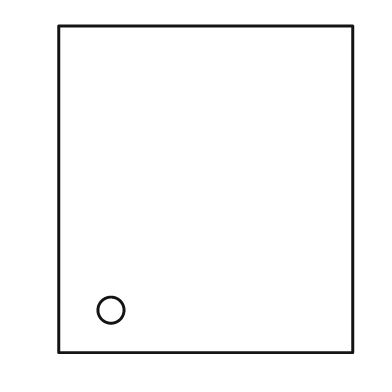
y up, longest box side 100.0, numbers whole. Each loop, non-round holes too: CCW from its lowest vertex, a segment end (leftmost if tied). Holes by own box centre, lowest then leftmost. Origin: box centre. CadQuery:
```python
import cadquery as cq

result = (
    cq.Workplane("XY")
    .moveTo(-45.0, -50.0)
    .lineTo(45.0, -50.0)
    .lineTo(45.0, 50.0)
    .lineTo(-45.0, 50.0)
    .close()
    .moveTo(-29.0, -37.0)
    .circle(4.0)
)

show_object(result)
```